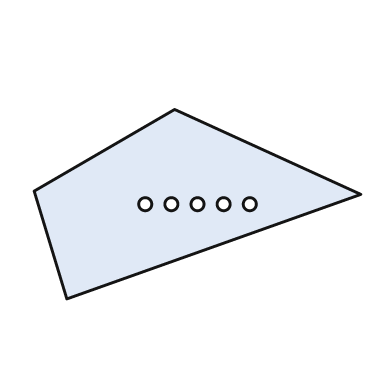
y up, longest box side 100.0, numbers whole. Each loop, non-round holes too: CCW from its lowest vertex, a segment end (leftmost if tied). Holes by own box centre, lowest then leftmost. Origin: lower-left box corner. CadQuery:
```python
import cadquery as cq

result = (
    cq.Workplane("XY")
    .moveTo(10.0, 0.0)
    .lineTo(100.0, 32.0)
    .lineTo(43.0, 58.0)
    .lineTo(0.0, 33.0)
    .close()
    .moveTo(34.0, 29.0)
    .circle(2.0)
    .moveTo(42.0, 29.0)
    .circle(2.0)
    .moveTo(50.0, 29.0)
    .circle(2.0)
    .moveTo(58.0, 29.0)
    .circle(2.0)
    .moveTo(66.0, 29.0)
    .circle(2.0)
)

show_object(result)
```